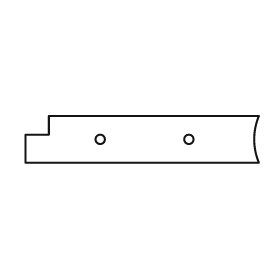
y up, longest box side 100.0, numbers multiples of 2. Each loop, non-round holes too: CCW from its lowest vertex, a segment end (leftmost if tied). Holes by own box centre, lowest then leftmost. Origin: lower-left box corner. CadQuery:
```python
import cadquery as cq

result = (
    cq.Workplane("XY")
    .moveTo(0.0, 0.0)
    .lineTo(100.0, 0.0)
    .threePointArc((98.0, 10.0), (100.0, 20.0))
    .lineTo(10.0, 20.0)
    .lineTo(10.0, 12.0)
    .lineTo(0.0, 12.0)
    .close()
    .moveTo(32.0, 10.0)
    .circle(2.0)
    .moveTo(70.0, 10.0)
    .circle(2.0)
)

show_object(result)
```